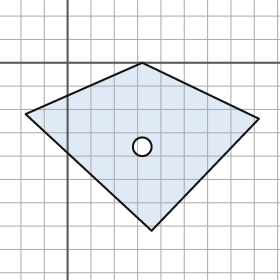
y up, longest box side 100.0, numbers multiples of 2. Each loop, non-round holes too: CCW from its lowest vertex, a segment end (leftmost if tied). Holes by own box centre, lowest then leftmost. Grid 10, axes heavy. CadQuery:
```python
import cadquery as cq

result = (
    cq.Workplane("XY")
    .moveTo(36.0, -72.0)
    .lineTo(82.0, -24.0)
    .lineTo(32.0, 0.0)
    .lineTo(-18.0, -22.0)
    .close()
    .moveTo(32.0, -36.0)
    .circle(4.0)
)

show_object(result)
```